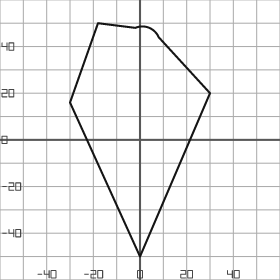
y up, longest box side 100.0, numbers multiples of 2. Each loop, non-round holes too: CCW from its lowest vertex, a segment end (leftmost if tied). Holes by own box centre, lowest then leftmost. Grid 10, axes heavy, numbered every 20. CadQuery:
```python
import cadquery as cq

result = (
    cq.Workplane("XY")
    .moveTo(0.0, -50.0)
    .lineTo(30.0, 20.0)
    .lineTo(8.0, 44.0)
    .threePointArc((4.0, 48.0), (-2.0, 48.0))
    .lineTo(-18.0, 50.0)
    .lineTo(-30.0, 16.0)
    .close()
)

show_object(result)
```